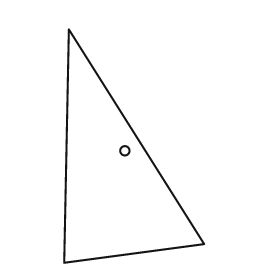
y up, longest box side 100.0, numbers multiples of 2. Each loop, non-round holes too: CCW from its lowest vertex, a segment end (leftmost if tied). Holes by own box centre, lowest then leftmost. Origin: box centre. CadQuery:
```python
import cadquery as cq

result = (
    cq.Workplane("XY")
    .moveTo(-30.0, -50.0)
    .lineTo(30.0, -42.0)
    .lineTo(-28.0, 50.0)
    .close()
    .moveTo(-4.0, -2.0)
    .circle(2.0)
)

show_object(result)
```